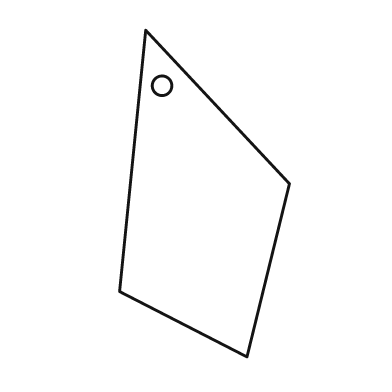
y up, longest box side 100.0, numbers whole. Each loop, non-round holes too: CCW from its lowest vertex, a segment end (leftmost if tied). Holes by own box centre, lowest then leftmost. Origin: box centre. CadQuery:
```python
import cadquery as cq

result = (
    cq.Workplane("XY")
    .moveTo(13.0, -50.0)
    .lineTo(26.0, 3.0)
    .lineTo(-18.0, 50.0)
    .lineTo(-26.0, -30.0)
    .close()
    .moveTo(-13.0, 33.0)
    .circle(3.0)
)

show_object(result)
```